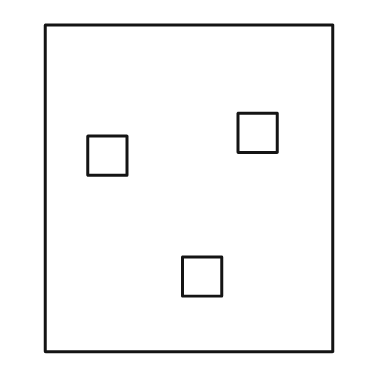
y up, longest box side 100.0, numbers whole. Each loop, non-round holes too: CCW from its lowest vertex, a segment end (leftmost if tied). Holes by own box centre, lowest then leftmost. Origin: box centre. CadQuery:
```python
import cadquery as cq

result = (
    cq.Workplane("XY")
    .moveTo(-44.0, -50.0)
    .lineTo(44.0, -50.0)
    .lineTo(44.0, 50.0)
    .lineTo(-44.0, 50.0)
    .close()
    .moveTo(-2.0, -33.0)
    .lineTo(10.0, -33.0)
    .lineTo(10.0, -21.0)
    .lineTo(-2.0, -21.0)
    .close()
    .moveTo(-31.0, 4.0)
    .lineTo(-19.0, 4.0)
    .lineTo(-19.0, 16.0)
    .lineTo(-31.0, 16.0)
    .close()
    .moveTo(15.0, 11.0)
    .lineTo(27.0, 11.0)
    .lineTo(27.0, 23.0)
    .lineTo(15.0, 23.0)
    .close()
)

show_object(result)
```